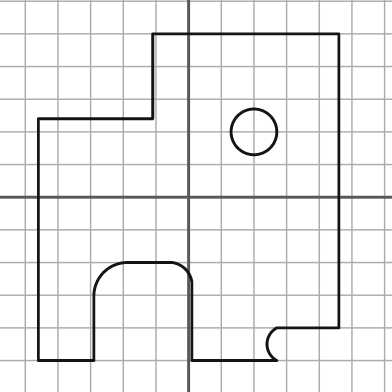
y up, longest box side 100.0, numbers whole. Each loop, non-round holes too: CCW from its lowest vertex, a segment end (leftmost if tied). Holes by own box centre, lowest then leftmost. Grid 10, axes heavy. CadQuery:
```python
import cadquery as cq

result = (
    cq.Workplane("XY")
    .moveTo(-46.0, -50.0)
    .lineTo(-29.0, -50.0)
    .lineTo(-29.0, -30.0)
    .threePointArc((-26.0, -23.0), (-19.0, -20.0))
    .lineTo(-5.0, -20.0)
    .threePointArc((-1.0, -22.0), (1.0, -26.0))
    .lineTo(1.0, -50.0)
    .lineTo(27.0, -50.0)
    .threePointArc((24.0, -45.0), (27.0, -40.0))
    .lineTo(46.0, -40.0)
    .lineTo(46.0, 50.0)
    .lineTo(-11.0, 50.0)
    .lineTo(-11.0, 24.0)
    .lineTo(-46.0, 24.0)
    .close()
    .moveTo(20.0, 20.0)
    .circle(7.0)
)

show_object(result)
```